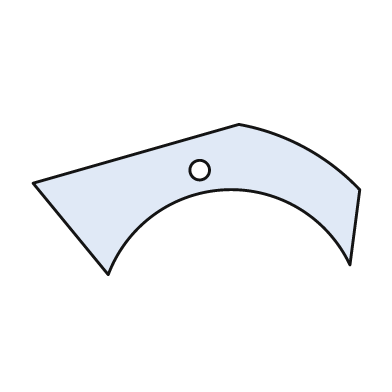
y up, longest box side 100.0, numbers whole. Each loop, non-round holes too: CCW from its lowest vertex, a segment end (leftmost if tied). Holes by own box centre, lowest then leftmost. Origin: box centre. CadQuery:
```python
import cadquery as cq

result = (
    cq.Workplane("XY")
    .moveTo(-27.0, -23.0)
    .threePointArc((9.0, 3.0), (47.0, -20.0))
    .lineTo(50.0, 3.0)
    .threePointArc((33.0, 16.0), (13.0, 23.0))
    .lineTo(-50.0, 5.0)
    .close()
    .moveTo(1.0, 9.0)
    .circle(3.0)
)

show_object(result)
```